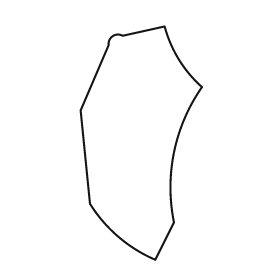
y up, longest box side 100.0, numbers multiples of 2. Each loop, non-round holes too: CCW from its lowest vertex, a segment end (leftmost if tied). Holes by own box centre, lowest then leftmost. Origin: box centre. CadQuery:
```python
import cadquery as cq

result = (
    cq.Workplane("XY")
    .moveTo(6.0, -50.0)
    .lineTo(14.0, -34.0)
    .threePointArc((14.0, -4.0), (26.0, 24.0))
    .threePointArc((16.0, 36.0), (10.0, 50.0))
    .lineTo(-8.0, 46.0)
    .threePointArc((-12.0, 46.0), (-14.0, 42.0))
    .lineTo(-26.0, 14.0)
    .lineTo(-22.0, -26.0)
    .threePointArc((-10.0, -40.0), (6.0, -50.0))
    .close()
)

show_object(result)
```